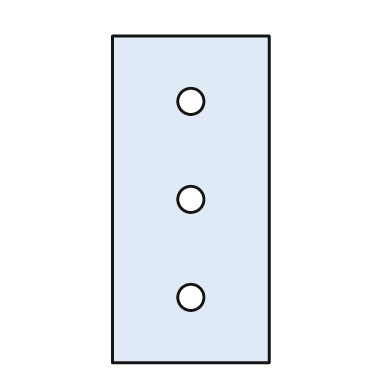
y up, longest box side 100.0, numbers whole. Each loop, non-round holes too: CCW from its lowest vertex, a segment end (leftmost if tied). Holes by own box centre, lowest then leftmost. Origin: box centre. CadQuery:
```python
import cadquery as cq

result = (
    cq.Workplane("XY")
    .moveTo(-24.0, -50.0)
    .lineTo(24.0, -50.0)
    .lineTo(24.0, 50.0)
    .lineTo(-24.0, 50.0)
    .close()
    .moveTo(0.0, -30.0)
    .circle(4.0)
    .moveTo(0.0, 0.0)
    .circle(4.0)
    .moveTo(0.0, 30.0)
    .circle(4.0)
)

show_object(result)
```